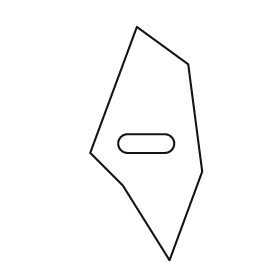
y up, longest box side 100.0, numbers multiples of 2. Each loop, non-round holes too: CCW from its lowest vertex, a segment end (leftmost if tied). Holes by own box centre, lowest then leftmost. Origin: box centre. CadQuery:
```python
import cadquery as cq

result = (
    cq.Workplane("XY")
    .moveTo(10.0, -50.0)
    .lineTo(24.0, -12.0)
    .lineTo(18.0, 34.0)
    .lineTo(-4.0, 50.0)
    .lineTo(-24.0, -4.0)
    .lineTo(-10.0, -18.0)
    .close()
    .moveTo(-8.0, -4.0)
    .lineTo(8.0, -4.0)
    .threePointArc((12.0, 0.0), (8.0, 4.0))
    .lineTo(-8.0, 4.0)
    .threePointArc((-12.0, 0.0), (-8.0, -4.0))
    .close()
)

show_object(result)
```